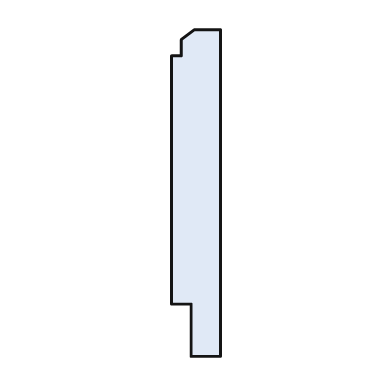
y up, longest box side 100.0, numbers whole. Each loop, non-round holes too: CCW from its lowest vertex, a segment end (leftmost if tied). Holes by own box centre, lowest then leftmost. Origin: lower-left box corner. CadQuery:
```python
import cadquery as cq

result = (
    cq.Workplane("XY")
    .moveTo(6.0, 0.0)
    .lineTo(15.0, 0.0)
    .lineTo(15.0, 100.0)
    .lineTo(7.0, 100.0)
    .lineTo(3.0, 97.0)
    .lineTo(3.0, 92.0)
    .lineTo(0.0, 92.0)
    .lineTo(0.0, 16.0)
    .lineTo(6.0, 16.0)
    .close()
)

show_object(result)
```